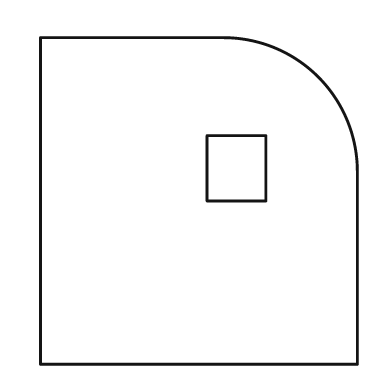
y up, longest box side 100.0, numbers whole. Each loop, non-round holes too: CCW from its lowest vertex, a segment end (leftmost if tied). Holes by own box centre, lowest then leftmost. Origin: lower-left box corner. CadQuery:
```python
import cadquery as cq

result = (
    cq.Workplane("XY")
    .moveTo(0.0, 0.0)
    .lineTo(97.0, 0.0)
    .lineTo(97.0, 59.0)
    .threePointArc((85.0, 88.0), (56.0, 100.0))
    .lineTo(0.0, 100.0)
    .close()
    .moveTo(51.0, 50.0)
    .lineTo(69.0, 50.0)
    .lineTo(69.0, 70.0)
    .lineTo(51.0, 70.0)
    .close()
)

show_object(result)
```